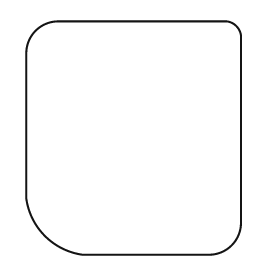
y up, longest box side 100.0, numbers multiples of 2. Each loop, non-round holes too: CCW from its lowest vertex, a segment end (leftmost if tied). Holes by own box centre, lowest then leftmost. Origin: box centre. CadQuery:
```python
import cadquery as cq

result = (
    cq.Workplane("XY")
    .moveTo(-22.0, -50.0)
    .lineTo(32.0, -50.0)
    .threePointArc((42.0, -46.0), (46.0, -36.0))
    .lineTo(46.0, 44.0)
    .threePointArc((44.0, 48.0), (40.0, 50.0))
    .lineTo(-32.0, 50.0)
    .threePointArc((-42.0, 46.0), (-46.0, 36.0))
    .lineTo(-46.0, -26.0)
    .threePointArc((-38.0, -42.0), (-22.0, -50.0))
    .close()
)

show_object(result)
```